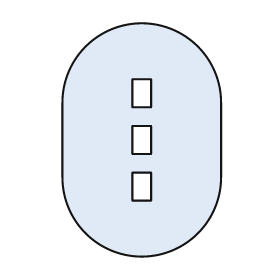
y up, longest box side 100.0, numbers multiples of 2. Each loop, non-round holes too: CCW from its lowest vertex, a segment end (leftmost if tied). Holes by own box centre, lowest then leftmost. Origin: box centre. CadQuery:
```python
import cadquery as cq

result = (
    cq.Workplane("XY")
    .moveTo(-34.0, -16.0)
    .threePointArc((0.0, -50.0), (34.0, -16.0))
    .lineTo(34.0, 16.0)
    .threePointArc((0.0, 50.0), (-34.0, 16.0))
    .close()
    .moveTo(-4.0, -26.0)
    .lineTo(4.0, -26.0)
    .lineTo(4.0, -14.0)
    .lineTo(-4.0, -14.0)
    .close()
    .moveTo(-4.0, -6.0)
    .lineTo(4.0, -6.0)
    .lineTo(4.0, 6.0)
    .lineTo(-4.0, 6.0)
    .close()
    .moveTo(-4.0, 14.0)
    .lineTo(4.0, 14.0)
    .lineTo(4.0, 26.0)
    .lineTo(-4.0, 26.0)
    .close()
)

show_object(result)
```